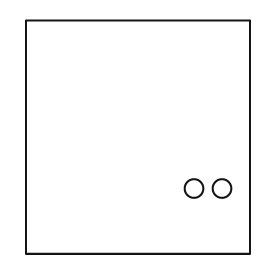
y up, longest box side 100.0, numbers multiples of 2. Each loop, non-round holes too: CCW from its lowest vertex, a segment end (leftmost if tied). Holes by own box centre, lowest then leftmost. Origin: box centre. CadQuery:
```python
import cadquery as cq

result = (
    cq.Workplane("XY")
    .moveTo(-48.0, -50.0)
    .lineTo(48.0, -50.0)
    .lineTo(48.0, 50.0)
    .lineTo(-48.0, 50.0)
    .close()
    .moveTo(24.0, -22.0)
    .circle(4.0)
    .moveTo(36.0, -22.0)
    .circle(4.0)
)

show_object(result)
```